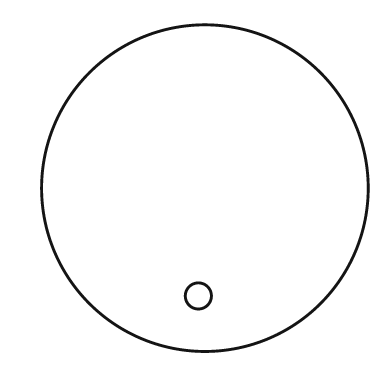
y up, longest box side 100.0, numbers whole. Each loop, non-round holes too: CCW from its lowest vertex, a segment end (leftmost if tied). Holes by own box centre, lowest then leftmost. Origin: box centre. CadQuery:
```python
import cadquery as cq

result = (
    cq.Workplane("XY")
    .moveTo(0.0, 0.0)
    .circle(50.0)
    .moveTo(-2.0, -33.0)
    .circle(4.0)
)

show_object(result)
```